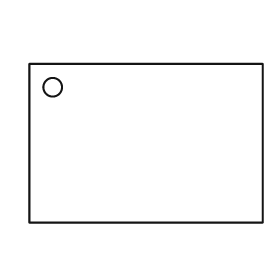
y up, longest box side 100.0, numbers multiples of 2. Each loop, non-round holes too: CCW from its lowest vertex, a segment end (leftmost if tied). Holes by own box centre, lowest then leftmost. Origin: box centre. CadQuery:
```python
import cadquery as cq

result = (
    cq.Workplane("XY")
    .moveTo(-50.0, -34.0)
    .lineTo(50.0, -34.0)
    .lineTo(50.0, 34.0)
    .lineTo(-50.0, 34.0)
    .close()
    .moveTo(-40.0, 24.0)
    .circle(4.0)
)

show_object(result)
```